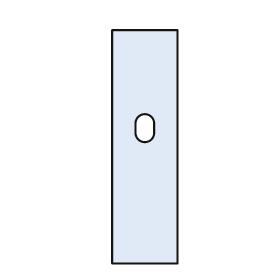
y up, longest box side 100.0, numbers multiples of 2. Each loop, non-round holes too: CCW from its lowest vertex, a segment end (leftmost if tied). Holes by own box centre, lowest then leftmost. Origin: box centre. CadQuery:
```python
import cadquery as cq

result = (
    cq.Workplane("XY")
    .moveTo(-14.0, -50.0)
    .lineTo(14.0, -50.0)
    .lineTo(14.0, 50.0)
    .lineTo(-14.0, 50.0)
    .close()
    .moveTo(-4.0, 6.0)
    .threePointArc((0.0, 2.0), (4.0, 6.0))
    .lineTo(4.0, 10.0)
    .threePointArc((0.0, 14.0), (-4.0, 10.0))
    .close()
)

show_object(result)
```